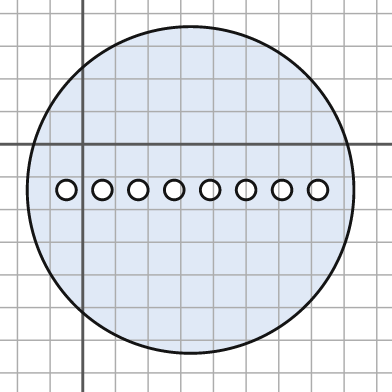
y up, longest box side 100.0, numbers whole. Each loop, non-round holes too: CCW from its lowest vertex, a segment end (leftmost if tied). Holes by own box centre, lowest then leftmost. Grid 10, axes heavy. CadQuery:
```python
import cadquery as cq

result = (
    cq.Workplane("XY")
    .moveTo(33.0, -14.0)
    .circle(50.0)
    .moveTo(-5.0, -14.0)
    .circle(3.0)
    .moveTo(6.0, -14.0)
    .circle(3.0)
    .moveTo(17.0, -14.0)
    .circle(3.0)
    .moveTo(28.0, -14.0)
    .circle(3.0)
    .moveTo(39.0, -14.0)
    .circle(3.0)
    .moveTo(50.0, -14.0)
    .circle(3.0)
    .moveTo(61.0, -14.0)
    .circle(3.0)
    .moveTo(72.0, -14.0)
    .circle(3.0)
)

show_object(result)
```